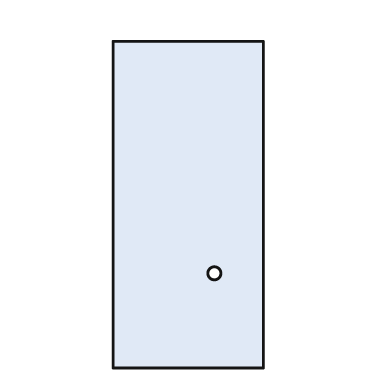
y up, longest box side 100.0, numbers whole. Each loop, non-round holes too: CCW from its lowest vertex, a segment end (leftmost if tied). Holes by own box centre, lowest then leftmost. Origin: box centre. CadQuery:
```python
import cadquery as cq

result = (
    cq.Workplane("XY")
    .moveTo(-23.0, -50.0)
    .lineTo(23.0, -50.0)
    .lineTo(23.0, 50.0)
    .lineTo(-23.0, 50.0)
    .close()
    .moveTo(8.0, -21.0)
    .circle(2.0)
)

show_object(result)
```